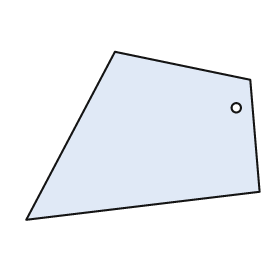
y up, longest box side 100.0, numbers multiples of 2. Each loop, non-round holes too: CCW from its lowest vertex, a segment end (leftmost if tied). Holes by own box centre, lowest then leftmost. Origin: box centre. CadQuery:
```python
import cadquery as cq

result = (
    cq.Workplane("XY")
    .moveTo(-50.0, -36.0)
    .lineTo(50.0, -24.0)
    .lineTo(46.0, 24.0)
    .lineTo(-12.0, 36.0)
    .close()
    .moveTo(40.0, 12.0)
    .circle(2.0)
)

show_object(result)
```